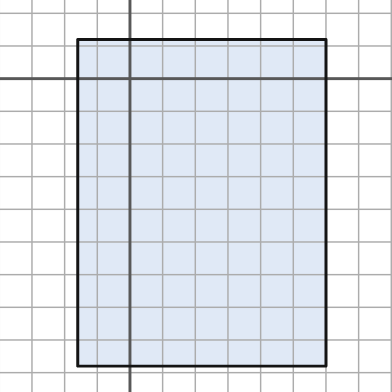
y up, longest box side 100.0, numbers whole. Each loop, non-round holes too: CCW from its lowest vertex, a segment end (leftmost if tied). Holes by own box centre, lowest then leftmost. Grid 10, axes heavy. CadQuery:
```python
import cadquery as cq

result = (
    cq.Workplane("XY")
    .moveTo(-16.0, -88.0)
    .lineTo(60.0, -88.0)
    .lineTo(60.0, 12.0)
    .lineTo(-16.0, 12.0)
    .close()
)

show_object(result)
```